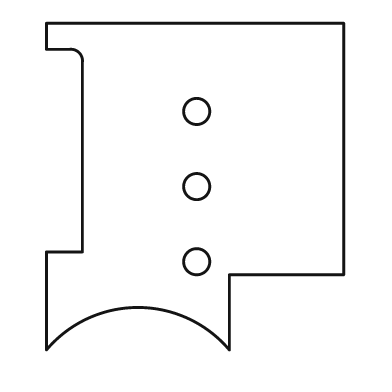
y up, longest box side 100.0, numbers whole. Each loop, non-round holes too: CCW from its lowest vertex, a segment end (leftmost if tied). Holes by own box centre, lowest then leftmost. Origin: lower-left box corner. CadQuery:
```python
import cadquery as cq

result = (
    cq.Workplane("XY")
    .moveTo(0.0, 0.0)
    .threePointArc((28.0, 13.0), (56.0, 0.0))
    .lineTo(56.0, 23.0)
    .lineTo(91.0, 23.0)
    .lineTo(91.0, 100.0)
    .lineTo(0.0, 100.0)
    .lineTo(0.0, 92.0)
    .lineTo(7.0, 92.0)
    .threePointArc((10.0, 91.0), (11.0, 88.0))
    .lineTo(11.0, 30.0)
    .lineTo(0.0, 30.0)
    .close()
    .moveTo(46.0, 27.0)
    .circle(4.0)
    .moveTo(46.0, 50.0)
    .circle(4.0)
    .moveTo(46.0, 73.0)
    .circle(4.0)
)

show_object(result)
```